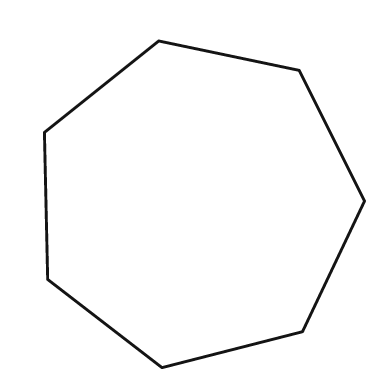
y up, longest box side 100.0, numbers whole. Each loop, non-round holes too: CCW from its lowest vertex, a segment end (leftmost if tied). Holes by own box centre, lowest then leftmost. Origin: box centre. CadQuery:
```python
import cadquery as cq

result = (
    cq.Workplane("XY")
    .moveTo(-13.0, -50.0)
    .lineTo(30.0, -39.0)
    .lineTo(49.0, 1.0)
    .lineTo(29.0, 41.0)
    .lineTo(-14.0, 50.0)
    .lineTo(-49.0, 22.0)
    .lineTo(-48.0, -23.0)
    .close()
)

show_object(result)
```